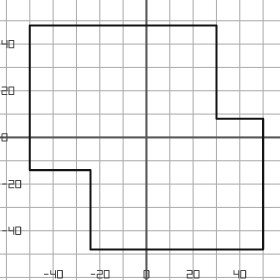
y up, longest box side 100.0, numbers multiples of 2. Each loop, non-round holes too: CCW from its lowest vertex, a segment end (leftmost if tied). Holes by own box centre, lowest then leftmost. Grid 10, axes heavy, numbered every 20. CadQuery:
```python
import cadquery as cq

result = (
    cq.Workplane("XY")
    .moveTo(-24.0, -48.0)
    .lineTo(50.0, -48.0)
    .lineTo(50.0, 8.0)
    .lineTo(30.0, 8.0)
    .lineTo(30.0, 48.0)
    .lineTo(-50.0, 48.0)
    .lineTo(-50.0, -14.0)
    .lineTo(-24.0, -14.0)
    .close()
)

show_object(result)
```